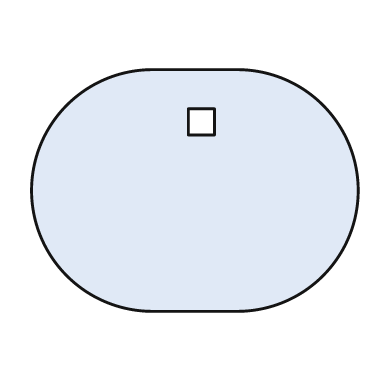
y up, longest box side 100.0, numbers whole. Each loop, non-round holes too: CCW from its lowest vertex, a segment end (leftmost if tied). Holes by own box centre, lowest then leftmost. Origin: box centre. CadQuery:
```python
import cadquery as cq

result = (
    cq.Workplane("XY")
    .moveTo(-13.0, -37.0)
    .lineTo(13.0, -37.0)
    .threePointArc((50.0, 0.0), (13.0, 37.0))
    .lineTo(-13.0, 37.0)
    .threePointArc((-50.0, 0.0), (-13.0, -37.0))
    .close()
    .moveTo(-2.0, 17.0)
    .lineTo(6.0, 17.0)
    .lineTo(6.0, 25.0)
    .lineTo(-2.0, 25.0)
    .close()
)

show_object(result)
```